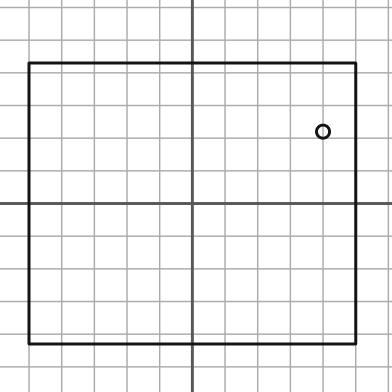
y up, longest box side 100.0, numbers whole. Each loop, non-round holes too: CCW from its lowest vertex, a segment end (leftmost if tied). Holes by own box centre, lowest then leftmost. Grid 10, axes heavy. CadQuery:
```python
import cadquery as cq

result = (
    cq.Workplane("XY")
    .moveTo(-50.0, -43.0)
    .lineTo(50.0, -43.0)
    .lineTo(50.0, 43.0)
    .lineTo(-50.0, 43.0)
    .close()
    .moveTo(40.0, 22.0)
    .circle(2.0)
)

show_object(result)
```